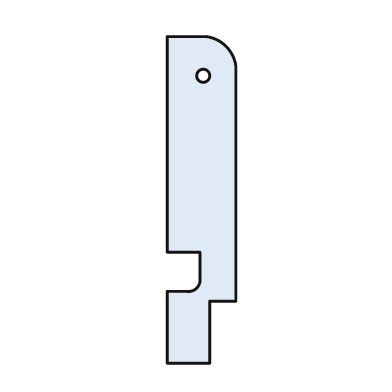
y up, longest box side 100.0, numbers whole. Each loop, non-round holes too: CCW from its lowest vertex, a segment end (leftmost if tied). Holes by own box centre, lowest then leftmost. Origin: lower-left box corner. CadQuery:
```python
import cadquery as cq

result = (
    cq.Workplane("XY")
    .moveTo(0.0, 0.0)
    .lineTo(13.0, 0.0)
    .lineTo(13.0, 19.0)
    .lineTo(21.0, 19.0)
    .lineTo(21.0, 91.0)
    .threePointArc((18.0, 97.0), (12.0, 100.0))
    .lineTo(0.0, 100.0)
    .lineTo(0.0, 34.0)
    .lineTo(10.0, 34.0)
    .lineTo(10.0, 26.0)
    .threePointArc((9.0, 23.0), (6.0, 22.0))
    .lineTo(0.0, 22.0)
    .close()
    .moveTo(11.0, 88.0)
    .circle(2.0)
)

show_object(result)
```